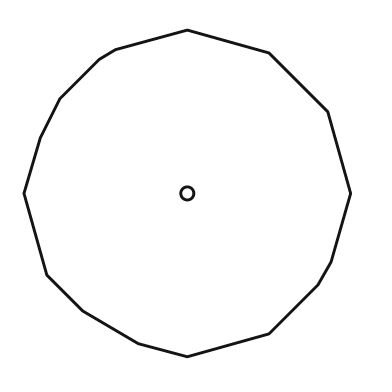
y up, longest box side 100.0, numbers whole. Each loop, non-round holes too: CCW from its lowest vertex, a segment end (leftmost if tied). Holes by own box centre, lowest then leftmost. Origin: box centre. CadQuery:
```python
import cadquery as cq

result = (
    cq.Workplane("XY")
    .moveTo(0.0, -50.0)
    .lineTo(25.0, -43.0)
    .lineTo(40.0, -28.0)
    .lineTo(44.0, -21.0)
    .lineTo(50.0, 0.0)
    .lineTo(43.0, 25.0)
    .lineTo(25.0, 43.0)
    .lineTo(0.0, 50.0)
    .lineTo(-22.0, 44.0)
    .lineTo(-27.0, 41.0)
    .lineTo(-39.0, 29.0)
    .lineTo(-45.0, 17.0)
    .lineTo(-50.0, 0.0)
    .lineTo(-43.0, -25.0)
    .lineTo(-32.0, -36.0)
    .lineTo(-15.0, -46.0)
    .close()
    .moveTo(0.0, 0.0)
    .circle(2.0)
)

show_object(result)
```